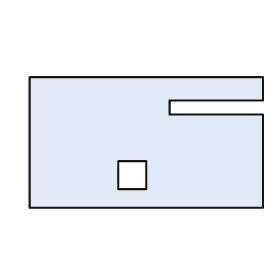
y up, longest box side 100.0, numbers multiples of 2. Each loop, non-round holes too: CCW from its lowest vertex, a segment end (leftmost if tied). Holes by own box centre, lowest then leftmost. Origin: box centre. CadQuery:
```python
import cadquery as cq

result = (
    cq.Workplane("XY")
    .moveTo(-50.0, -28.0)
    .lineTo(50.0, -28.0)
    .lineTo(50.0, 12.0)
    .lineTo(10.0, 12.0)
    .lineTo(10.0, 18.0)
    .lineTo(50.0, 18.0)
    .lineTo(50.0, 28.0)
    .lineTo(-50.0, 28.0)
    .close()
    .moveTo(-12.0, -20.0)
    .lineTo(0.0, -20.0)
    .lineTo(0.0, -8.0)
    .lineTo(-12.0, -8.0)
    .close()
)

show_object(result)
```